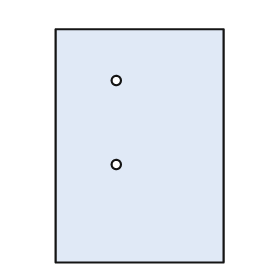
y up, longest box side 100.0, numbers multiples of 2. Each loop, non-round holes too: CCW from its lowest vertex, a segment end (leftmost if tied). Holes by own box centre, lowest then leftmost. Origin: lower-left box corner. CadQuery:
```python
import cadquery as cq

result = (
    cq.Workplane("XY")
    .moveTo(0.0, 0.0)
    .lineTo(72.0, 0.0)
    .lineTo(72.0, 100.0)
    .lineTo(0.0, 100.0)
    .close()
    .moveTo(26.0, 42.0)
    .circle(2.0)
    .moveTo(26.0, 78.0)
    .circle(2.0)
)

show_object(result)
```